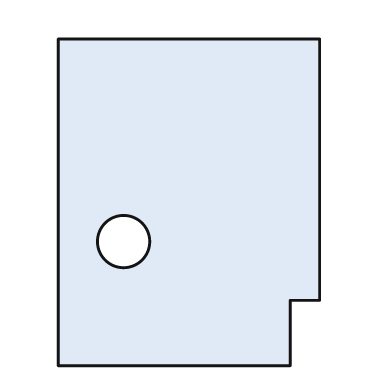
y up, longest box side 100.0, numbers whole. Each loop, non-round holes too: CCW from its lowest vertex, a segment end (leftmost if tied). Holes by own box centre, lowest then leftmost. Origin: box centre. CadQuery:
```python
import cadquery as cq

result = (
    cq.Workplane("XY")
    .moveTo(-40.0, -50.0)
    .lineTo(31.0, -50.0)
    .lineTo(31.0, -30.0)
    .lineTo(40.0, -30.0)
    .lineTo(40.0, 50.0)
    .lineTo(-40.0, 50.0)
    .close()
    .moveTo(-20.0, -12.0)
    .circle(8.0)
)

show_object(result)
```